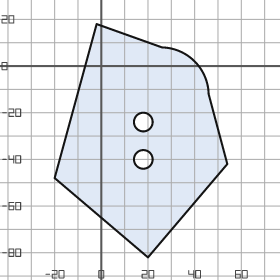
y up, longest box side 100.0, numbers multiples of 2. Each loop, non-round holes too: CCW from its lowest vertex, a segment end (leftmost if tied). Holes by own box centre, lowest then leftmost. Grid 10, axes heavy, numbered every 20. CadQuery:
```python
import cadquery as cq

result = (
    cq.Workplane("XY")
    .moveTo(20.0, -82.0)
    .lineTo(54.0, -42.0)
    .lineTo(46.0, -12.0)
    .threePointArc((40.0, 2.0), (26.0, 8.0))
    .lineTo(-2.0, 18.0)
    .lineTo(-20.0, -48.0)
    .close()
    .moveTo(18.0, -40.0)
    .circle(4.0)
    .moveTo(18.0, -24.0)
    .circle(4.0)
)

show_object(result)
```